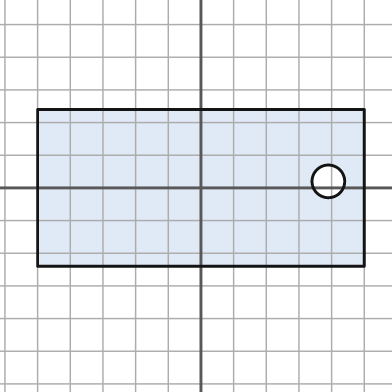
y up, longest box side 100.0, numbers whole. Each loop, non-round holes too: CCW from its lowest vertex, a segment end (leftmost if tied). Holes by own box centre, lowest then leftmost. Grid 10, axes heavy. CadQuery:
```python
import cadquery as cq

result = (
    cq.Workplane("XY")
    .moveTo(-50.0, -24.0)
    .lineTo(50.0, -24.0)
    .lineTo(50.0, 24.0)
    .lineTo(-50.0, 24.0)
    .close()
    .moveTo(39.0, 2.0)
    .circle(5.0)
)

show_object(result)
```